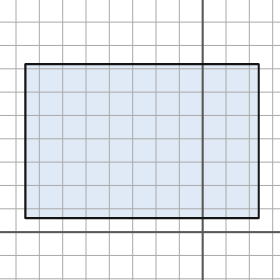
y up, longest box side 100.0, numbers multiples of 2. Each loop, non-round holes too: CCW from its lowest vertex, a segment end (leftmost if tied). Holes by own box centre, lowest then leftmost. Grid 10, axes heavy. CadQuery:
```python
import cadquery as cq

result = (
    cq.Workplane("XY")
    .moveTo(-76.0, 6.0)
    .lineTo(24.0, 6.0)
    .lineTo(24.0, 72.0)
    .lineTo(-76.0, 72.0)
    .close()
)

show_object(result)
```